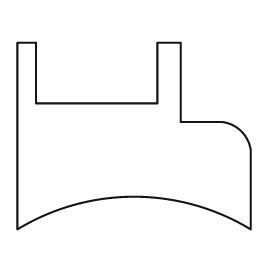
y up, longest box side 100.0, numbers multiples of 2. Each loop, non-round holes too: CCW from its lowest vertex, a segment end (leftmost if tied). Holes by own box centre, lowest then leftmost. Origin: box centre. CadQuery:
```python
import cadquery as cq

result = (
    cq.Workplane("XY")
    .moveTo(-50.0, -40.0)
    .threePointArc((0.0, -26.0), (50.0, -40.0))
    .lineTo(50.0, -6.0)
    .threePointArc((46.0, 2.0), (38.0, 6.0))
    .lineTo(20.0, 6.0)
    .lineTo(20.0, 40.0)
    .lineTo(10.0, 40.0)
    .lineTo(10.0, 14.0)
    .lineTo(-42.0, 14.0)
    .lineTo(-42.0, 40.0)
    .lineTo(-50.0, 40.0)
    .close()
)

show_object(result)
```